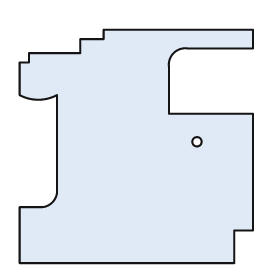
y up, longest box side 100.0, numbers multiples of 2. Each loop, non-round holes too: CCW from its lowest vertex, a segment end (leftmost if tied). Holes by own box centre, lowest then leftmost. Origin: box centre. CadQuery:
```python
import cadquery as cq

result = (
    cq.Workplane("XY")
    .moveTo(-50.0, -50.0)
    .lineTo(42.0, -50.0)
    .lineTo(42.0, -36.0)
    .lineTo(50.0, -36.0)
    .lineTo(50.0, 14.0)
    .lineTo(14.0, 14.0)
    .lineTo(14.0, 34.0)
    .threePointArc((16.0, 40.0), (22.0, 42.0))
    .lineTo(50.0, 42.0)
    .lineTo(50.0, 50.0)
    .lineTo(-14.0, 50.0)
    .lineTo(-14.0, 46.0)
    .lineTo(-24.0, 46.0)
    .lineTo(-24.0, 40.0)
    .lineTo(-46.0, 40.0)
    .lineTo(-46.0, 36.0)
    .lineTo(-50.0, 36.0)
    .lineTo(-50.0, 22.0)
    .threePointArc((-42.0, 20.0), (-34.0, 22.0))
    .lineTo(-34.0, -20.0)
    .threePointArc((-36.0, -24.0), (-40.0, -26.0))
    .lineTo(-50.0, -26.0)
    .close()
    .moveTo(26.0, 2.0)
    .circle(2.0)
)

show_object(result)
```